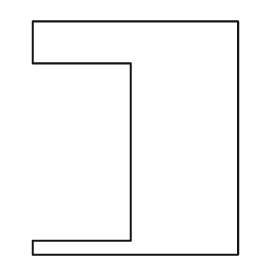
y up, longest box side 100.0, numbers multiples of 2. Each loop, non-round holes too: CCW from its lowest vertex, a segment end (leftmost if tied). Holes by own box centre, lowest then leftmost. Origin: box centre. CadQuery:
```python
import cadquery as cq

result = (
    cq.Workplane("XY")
    .moveTo(-44.0, -50.0)
    .lineTo(44.0, -50.0)
    .lineTo(44.0, 50.0)
    .lineTo(-44.0, 50.0)
    .lineTo(-44.0, 32.0)
    .lineTo(-2.0, 32.0)
    .lineTo(-2.0, -44.0)
    .lineTo(-44.0, -44.0)
    .close()
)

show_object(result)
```